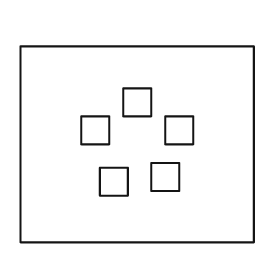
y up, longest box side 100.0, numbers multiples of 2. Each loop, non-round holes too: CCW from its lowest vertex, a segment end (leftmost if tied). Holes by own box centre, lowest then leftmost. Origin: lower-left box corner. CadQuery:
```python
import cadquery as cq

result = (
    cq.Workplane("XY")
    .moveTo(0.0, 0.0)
    .lineTo(100.0, 0.0)
    .lineTo(100.0, 84.0)
    .lineTo(0.0, 84.0)
    .close()
    .moveTo(34.0, 20.0)
    .lineTo(46.0, 20.0)
    .lineTo(46.0, 32.0)
    .lineTo(34.0, 32.0)
    .close()
    .moveTo(56.0, 22.0)
    .lineTo(68.0, 22.0)
    .lineTo(68.0, 34.0)
    .lineTo(56.0, 34.0)
    .close()
    .moveTo(26.0, 42.0)
    .lineTo(38.0, 42.0)
    .lineTo(38.0, 54.0)
    .lineTo(26.0, 54.0)
    .close()
    .moveTo(62.0, 42.0)
    .lineTo(74.0, 42.0)
    .lineTo(74.0, 54.0)
    .lineTo(62.0, 54.0)
    .close()
    .moveTo(44.0, 54.0)
    .lineTo(56.0, 54.0)
    .lineTo(56.0, 66.0)
    .lineTo(44.0, 66.0)
    .close()
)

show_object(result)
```